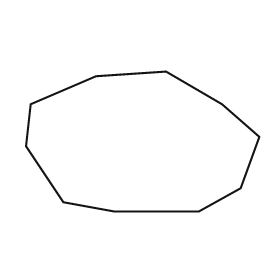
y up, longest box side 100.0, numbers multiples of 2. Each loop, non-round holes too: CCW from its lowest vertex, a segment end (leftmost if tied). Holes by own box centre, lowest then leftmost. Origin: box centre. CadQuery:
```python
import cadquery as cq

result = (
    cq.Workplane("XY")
    .moveTo(-12.0, -30.0)
    .lineTo(24.0, -30.0)
    .lineTo(42.0, -20.0)
    .lineTo(50.0, 2.0)
    .lineTo(34.0, 16.0)
    .lineTo(10.0, 30.0)
    .lineTo(-20.0, 28.0)
    .lineTo(-48.0, 16.0)
    .lineTo(-50.0, -2.0)
    .lineTo(-34.0, -26.0)
    .close()
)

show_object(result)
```